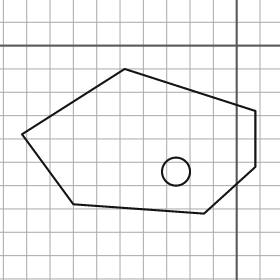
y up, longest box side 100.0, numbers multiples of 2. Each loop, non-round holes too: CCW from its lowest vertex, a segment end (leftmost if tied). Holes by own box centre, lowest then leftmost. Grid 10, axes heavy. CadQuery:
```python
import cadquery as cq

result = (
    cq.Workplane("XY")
    .moveTo(-14.0, -72.0)
    .lineTo(8.0, -52.0)
    .lineTo(8.0, -28.0)
    .lineTo(-48.0, -10.0)
    .lineTo(-92.0, -38.0)
    .lineTo(-70.0, -68.0)
    .close()
    .moveTo(-26.0, -54.0)
    .circle(6.0)
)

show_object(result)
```